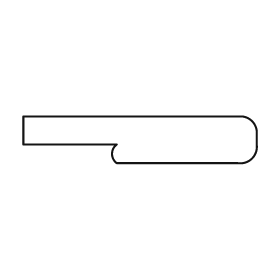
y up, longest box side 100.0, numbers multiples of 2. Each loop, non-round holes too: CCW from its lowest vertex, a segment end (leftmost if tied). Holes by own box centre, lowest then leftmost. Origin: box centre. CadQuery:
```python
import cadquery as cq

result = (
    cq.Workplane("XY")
    .moveTo(-10.0, -10.0)
    .lineTo(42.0, -10.0)
    .threePointArc((48.0, -8.0), (50.0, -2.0))
    .lineTo(50.0, 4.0)
    .threePointArc((48.0, 8.0), (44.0, 10.0))
    .lineTo(-50.0, 10.0)
    .lineTo(-50.0, -2.0)
    .lineTo(-10.0, -2.0)
    .threePointArc((-12.0, -6.0), (-10.0, -10.0))
    .close()
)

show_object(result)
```